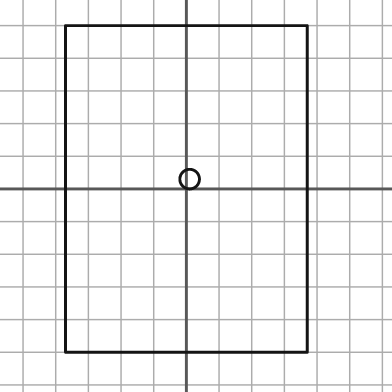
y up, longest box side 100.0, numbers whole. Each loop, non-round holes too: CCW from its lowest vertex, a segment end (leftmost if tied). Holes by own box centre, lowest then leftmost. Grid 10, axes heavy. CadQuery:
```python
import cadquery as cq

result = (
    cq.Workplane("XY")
    .moveTo(-37.0, -50.0)
    .lineTo(37.0, -50.0)
    .lineTo(37.0, 50.0)
    .lineTo(-37.0, 50.0)
    .close()
    .moveTo(1.0, 3.0)
    .circle(3.0)
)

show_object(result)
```